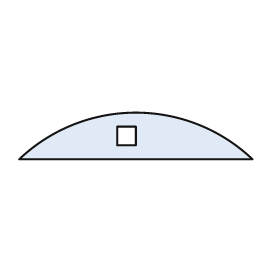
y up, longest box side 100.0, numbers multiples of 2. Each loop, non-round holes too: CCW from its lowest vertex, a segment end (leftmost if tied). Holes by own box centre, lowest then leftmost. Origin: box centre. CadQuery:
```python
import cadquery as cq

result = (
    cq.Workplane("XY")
    .moveTo(-50.0, -10.0)
    .lineTo(50.0, -10.0)
    .threePointArc((0.0, 10.0), (-50.0, -10.0))
    .close()
    .moveTo(-8.0, -4.0)
    .lineTo(0.0, -4.0)
    .lineTo(0.0, 4.0)
    .lineTo(-8.0, 4.0)
    .close()
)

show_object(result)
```